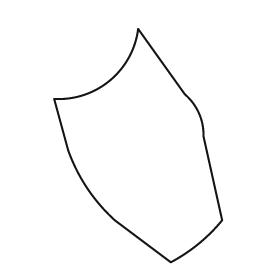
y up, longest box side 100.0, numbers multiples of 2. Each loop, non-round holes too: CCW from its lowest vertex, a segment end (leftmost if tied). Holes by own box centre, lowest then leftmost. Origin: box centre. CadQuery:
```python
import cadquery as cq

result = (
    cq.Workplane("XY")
    .moveTo(14.0, -50.0)
    .threePointArc((26.0, -42.0), (36.0, -32.0))
    .lineTo(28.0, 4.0)
    .threePointArc((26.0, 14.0), (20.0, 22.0))
    .lineTo(0.0, 50.0)
    .threePointArc((-12.0, 28.0), (-36.0, 20.0))
    .lineTo(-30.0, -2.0)
    .threePointArc((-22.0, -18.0), (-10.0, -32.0))
    .close()
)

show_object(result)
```